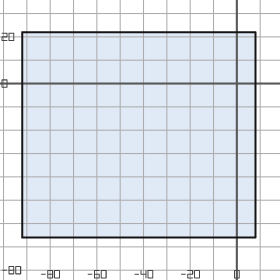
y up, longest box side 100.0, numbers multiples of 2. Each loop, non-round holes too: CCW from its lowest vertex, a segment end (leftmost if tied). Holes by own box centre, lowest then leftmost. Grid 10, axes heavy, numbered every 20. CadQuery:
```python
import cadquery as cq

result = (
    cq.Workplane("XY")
    .moveTo(-92.0, -66.0)
    .lineTo(8.0, -66.0)
    .lineTo(8.0, 22.0)
    .lineTo(-92.0, 22.0)
    .close()
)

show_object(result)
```